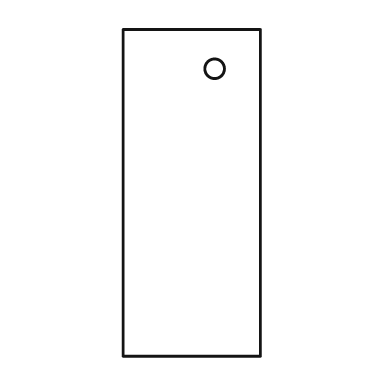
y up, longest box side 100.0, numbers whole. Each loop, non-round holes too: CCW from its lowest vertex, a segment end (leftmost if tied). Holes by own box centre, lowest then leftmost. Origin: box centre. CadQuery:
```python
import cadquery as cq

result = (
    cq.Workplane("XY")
    .moveTo(-21.0, -50.0)
    .lineTo(21.0, -50.0)
    .lineTo(21.0, 50.0)
    .lineTo(-21.0, 50.0)
    .close()
    .moveTo(7.0, 38.0)
    .circle(3.0)
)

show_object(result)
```